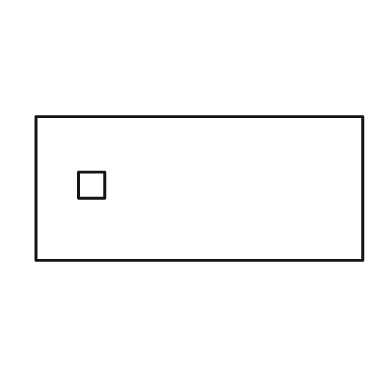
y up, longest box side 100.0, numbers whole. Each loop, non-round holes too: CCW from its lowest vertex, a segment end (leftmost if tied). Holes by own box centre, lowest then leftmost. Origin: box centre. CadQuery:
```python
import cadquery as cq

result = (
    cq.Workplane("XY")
    .moveTo(-50.0, -22.0)
    .lineTo(50.0, -22.0)
    .lineTo(50.0, 22.0)
    .lineTo(-50.0, 22.0)
    .close()
    .moveTo(-37.0, -3.0)
    .lineTo(-29.0, -3.0)
    .lineTo(-29.0, 5.0)
    .lineTo(-37.0, 5.0)
    .close()
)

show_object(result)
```